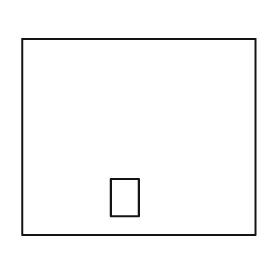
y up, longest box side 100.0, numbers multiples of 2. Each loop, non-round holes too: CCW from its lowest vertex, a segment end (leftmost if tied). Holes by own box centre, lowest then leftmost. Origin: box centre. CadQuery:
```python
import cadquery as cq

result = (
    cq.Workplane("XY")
    .moveTo(-50.0, -42.0)
    .lineTo(50.0, -42.0)
    .lineTo(50.0, 42.0)
    .lineTo(-50.0, 42.0)
    .close()
    .moveTo(-12.0, -34.0)
    .lineTo(0.0, -34.0)
    .lineTo(0.0, -18.0)
    .lineTo(-12.0, -18.0)
    .close()
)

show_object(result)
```